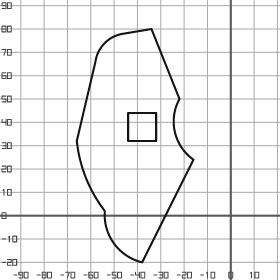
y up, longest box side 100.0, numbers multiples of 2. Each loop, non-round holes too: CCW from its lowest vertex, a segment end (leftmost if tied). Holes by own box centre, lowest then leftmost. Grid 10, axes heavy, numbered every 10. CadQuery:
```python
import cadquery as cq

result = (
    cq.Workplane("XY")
    .moveTo(-38.0, -20.0)
    .lineTo(-16.0, 24.0)
    .threePointArc((-24.0, 36.0), (-22.0, 50.0))
    .lineTo(-34.0, 80.0)
    .lineTo(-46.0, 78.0)
    .threePointArc((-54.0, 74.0), (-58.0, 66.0))
    .lineTo(-66.0, 32.0)
    .threePointArc((-62.0, 16.0), (-54.0, 2.0))
    .threePointArc((-50.0, -12.0), (-38.0, -20.0))
    .close()
    .moveTo(-44.0, 32.0)
    .lineTo(-32.0, 32.0)
    .lineTo(-32.0, 44.0)
    .lineTo(-44.0, 44.0)
    .close()
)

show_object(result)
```